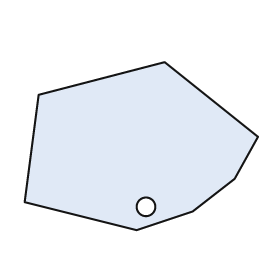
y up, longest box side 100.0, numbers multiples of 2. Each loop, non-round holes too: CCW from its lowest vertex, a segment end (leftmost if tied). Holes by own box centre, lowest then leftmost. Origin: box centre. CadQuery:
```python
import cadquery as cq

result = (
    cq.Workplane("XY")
    .moveTo(-2.0, -36.0)
    .lineTo(22.0, -28.0)
    .lineTo(40.0, -14.0)
    .lineTo(50.0, 4.0)
    .lineTo(10.0, 36.0)
    .lineTo(-44.0, 22.0)
    .lineTo(-50.0, -24.0)
    .close()
    .moveTo(2.0, -26.0)
    .circle(4.0)
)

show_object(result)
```